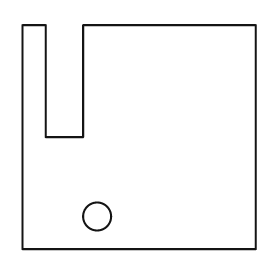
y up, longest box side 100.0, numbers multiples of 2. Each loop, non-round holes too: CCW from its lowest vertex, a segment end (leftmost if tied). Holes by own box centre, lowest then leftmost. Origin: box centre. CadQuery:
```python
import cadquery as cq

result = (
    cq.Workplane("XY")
    .moveTo(-50.0, -48.0)
    .lineTo(50.0, -48.0)
    .lineTo(50.0, 48.0)
    .lineTo(-24.0, 48.0)
    .lineTo(-24.0, 0.0)
    .lineTo(-40.0, 0.0)
    .lineTo(-40.0, 48.0)
    .lineTo(-50.0, 48.0)
    .close()
    .moveTo(-18.0, -34.0)
    .circle(6.0)
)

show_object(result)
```